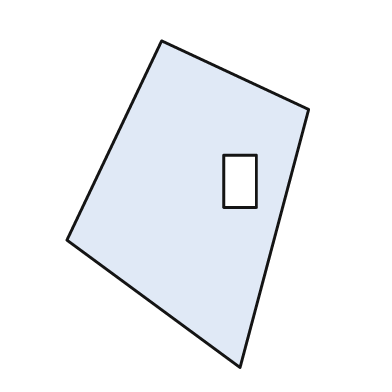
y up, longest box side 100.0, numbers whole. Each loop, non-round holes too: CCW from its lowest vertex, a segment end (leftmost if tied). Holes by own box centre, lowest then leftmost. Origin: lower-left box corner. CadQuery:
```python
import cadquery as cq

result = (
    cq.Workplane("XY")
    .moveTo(53.0, 0.0)
    .lineTo(74.0, 79.0)
    .lineTo(29.0, 100.0)
    .lineTo(0.0, 39.0)
    .close()
    .moveTo(48.0, 49.0)
    .lineTo(58.0, 49.0)
    .lineTo(58.0, 65.0)
    .lineTo(48.0, 65.0)
    .close()
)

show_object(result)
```